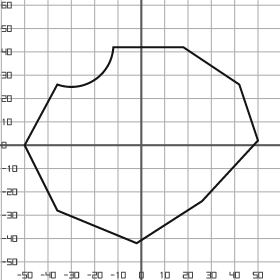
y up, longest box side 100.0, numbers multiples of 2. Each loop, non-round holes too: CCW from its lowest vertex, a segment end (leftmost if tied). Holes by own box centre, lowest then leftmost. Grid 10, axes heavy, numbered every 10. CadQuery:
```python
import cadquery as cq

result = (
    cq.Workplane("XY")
    .moveTo(-2.0, -42.0)
    .lineTo(26.0, -24.0)
    .lineTo(50.0, 2.0)
    .lineTo(42.0, 26.0)
    .lineTo(18.0, 42.0)
    .lineTo(-12.0, 42.0)
    .threePointArc((-20.0, 28.0), (-36.0, 26.0))
    .lineTo(-50.0, 0.0)
    .lineTo(-36.0, -28.0)
    .close()
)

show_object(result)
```